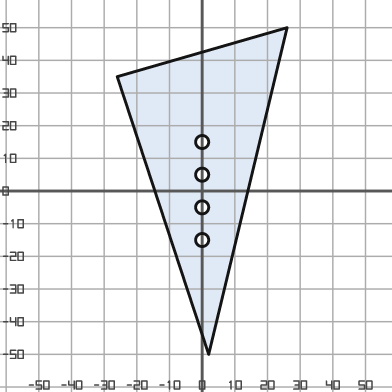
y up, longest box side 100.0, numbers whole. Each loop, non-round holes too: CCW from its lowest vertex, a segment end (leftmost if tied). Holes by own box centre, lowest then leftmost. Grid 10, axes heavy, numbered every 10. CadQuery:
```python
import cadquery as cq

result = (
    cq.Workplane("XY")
    .moveTo(2.0, -50.0)
    .lineTo(26.0, 50.0)
    .lineTo(-26.0, 35.0)
    .close()
    .moveTo(0.0, -15.0)
    .circle(2.0)
    .moveTo(0.0, -5.0)
    .circle(2.0)
    .moveTo(0.0, 5.0)
    .circle(2.0)
    .moveTo(0.0, 15.0)
    .circle(2.0)
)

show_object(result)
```